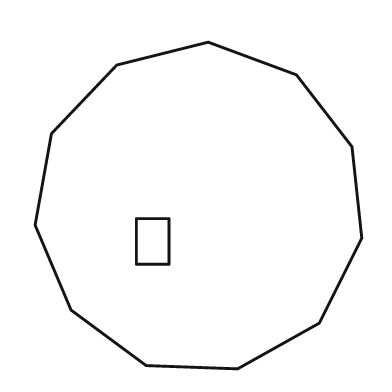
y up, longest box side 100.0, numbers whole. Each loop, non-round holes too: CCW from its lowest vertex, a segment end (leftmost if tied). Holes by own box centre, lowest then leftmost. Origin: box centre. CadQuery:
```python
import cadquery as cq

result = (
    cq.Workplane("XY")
    .moveTo(12.0, -50.0)
    .lineTo(37.0, -36.0)
    .lineTo(50.0, -10.0)
    .lineTo(47.0, 18.0)
    .lineTo(30.0, 40.0)
    .lineTo(3.0, 50.0)
    .lineTo(-25.0, 43.0)
    .lineTo(-45.0, 22.0)
    .lineTo(-50.0, -6.0)
    .lineTo(-39.0, -32.0)
    .lineTo(-16.0, -49.0)
    .close()
    .moveTo(-19.0, -18.0)
    .lineTo(-9.0, -18.0)
    .lineTo(-9.0, -4.0)
    .lineTo(-19.0, -4.0)
    .close()
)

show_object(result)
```